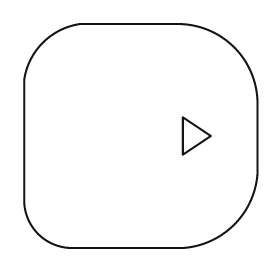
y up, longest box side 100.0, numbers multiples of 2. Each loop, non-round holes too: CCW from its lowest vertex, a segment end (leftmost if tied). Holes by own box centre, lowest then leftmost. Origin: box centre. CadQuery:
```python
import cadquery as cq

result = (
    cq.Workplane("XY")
    .moveTo(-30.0, -48.0)
    .lineTo(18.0, -48.0)
    .threePointArc((40.0, -38.0), (50.0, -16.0))
    .lineTo(50.0, 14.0)
    .threePointArc((40.0, 38.0), (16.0, 48.0))
    .lineTo(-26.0, 48.0)
    .threePointArc((-42.0, 40.0), (-50.0, 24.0))
    .lineTo(-50.0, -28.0)
    .threePointArc((-44.0, -42.0), (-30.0, -48.0))
    .close()
    .moveTo(18.0, -8.0)
    .lineTo(30.0, 0.0)
    .lineTo(18.0, 8.0)
    .close()
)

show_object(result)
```